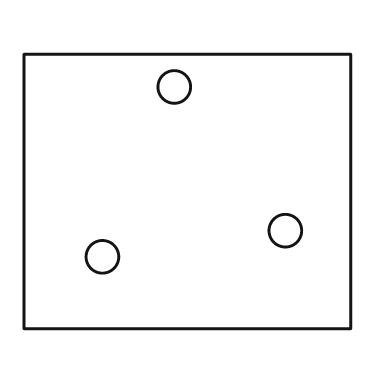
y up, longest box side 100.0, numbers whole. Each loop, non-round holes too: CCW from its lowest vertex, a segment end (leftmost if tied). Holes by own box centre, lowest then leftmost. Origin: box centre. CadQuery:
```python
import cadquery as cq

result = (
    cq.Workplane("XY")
    .moveTo(-50.0, -42.0)
    .lineTo(50.0, -42.0)
    .lineTo(50.0, 42.0)
    .lineTo(-50.0, 42.0)
    .close()
    .moveTo(-26.0, -20.0)
    .circle(5.0)
    .moveTo(30.0, -12.0)
    .circle(5.0)
    .moveTo(-4.0, 32.0)
    .circle(5.0)
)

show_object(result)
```